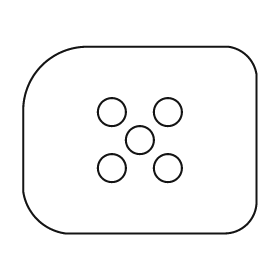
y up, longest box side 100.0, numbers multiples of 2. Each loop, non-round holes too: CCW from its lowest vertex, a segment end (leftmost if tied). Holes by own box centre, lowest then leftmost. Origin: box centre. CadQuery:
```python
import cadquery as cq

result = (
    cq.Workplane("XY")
    .moveTo(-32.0, -40.0)
    .lineTo(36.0, -40.0)
    .threePointArc((46.0, -36.0), (50.0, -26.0))
    .lineTo(50.0, 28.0)
    .threePointArc((46.0, 36.0), (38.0, 40.0))
    .lineTo(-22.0, 40.0)
    .threePointArc((-42.0, 32.0), (-50.0, 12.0))
    .lineTo(-50.0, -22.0)
    .threePointArc((-44.0, -34.0), (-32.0, -40.0))
    .close()
    .moveTo(-12.0, -12.0)
    .circle(6.0)
    .moveTo(12.0, -12.0)
    .circle(6.0)
    .moveTo(0.0, 0.0)
    .circle(6.0)
    .moveTo(-12.0, 12.0)
    .circle(6.0)
    .moveTo(12.0, 12.0)
    .circle(6.0)
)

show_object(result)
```